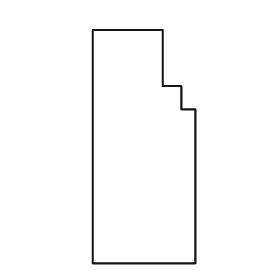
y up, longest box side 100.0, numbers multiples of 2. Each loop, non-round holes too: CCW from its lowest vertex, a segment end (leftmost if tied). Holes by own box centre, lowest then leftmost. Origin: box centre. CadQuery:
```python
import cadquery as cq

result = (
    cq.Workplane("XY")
    .moveTo(-22.0, -50.0)
    .lineTo(22.0, -50.0)
    .lineTo(22.0, 16.0)
    .lineTo(16.0, 16.0)
    .lineTo(16.0, 26.0)
    .lineTo(8.0, 26.0)
    .lineTo(8.0, 50.0)
    .lineTo(-22.0, 50.0)
    .close()
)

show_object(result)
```